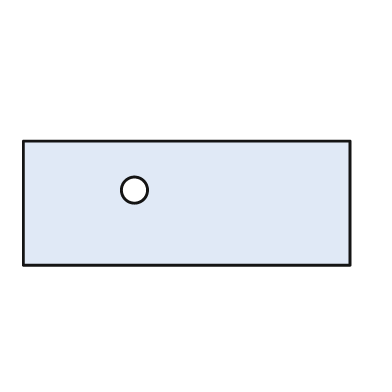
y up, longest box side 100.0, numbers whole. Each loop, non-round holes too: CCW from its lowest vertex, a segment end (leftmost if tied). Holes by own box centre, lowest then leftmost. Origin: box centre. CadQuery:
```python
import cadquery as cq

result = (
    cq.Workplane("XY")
    .moveTo(-50.0, -19.0)
    .lineTo(50.0, -19.0)
    .lineTo(50.0, 19.0)
    .lineTo(-50.0, 19.0)
    .close()
    .moveTo(-16.0, 4.0)
    .circle(4.0)
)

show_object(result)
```